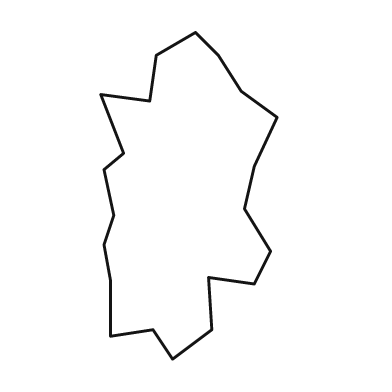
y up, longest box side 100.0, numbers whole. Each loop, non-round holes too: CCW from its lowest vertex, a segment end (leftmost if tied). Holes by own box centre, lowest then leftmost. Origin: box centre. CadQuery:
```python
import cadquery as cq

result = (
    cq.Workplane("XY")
    .moveTo(-5.0, -50.0)
    .lineTo(7.0, -41.0)
    .lineTo(6.0, -25.0)
    .lineTo(20.0, -27.0)
    .lineTo(25.0, -17.0)
    .lineTo(17.0, -4.0)
    .lineTo(20.0, 9.0)
    .lineTo(27.0, 24.0)
    .lineTo(16.0, 32.0)
    .lineTo(9.0, 43.0)
    .lineTo(2.0, 50.0)
    .lineTo(-10.0, 43.0)
    .lineTo(-12.0, 29.0)
    .lineTo(-27.0, 31.0)
    .lineTo(-20.0, 13.0)
    .lineTo(-26.0, 8.0)
    .lineTo(-23.0, -6.0)
    .lineTo(-26.0, -15.0)
    .lineTo(-24.0, -26.0)
    .lineTo(-24.0, -43.0)
    .lineTo(-11.0, -41.0)
    .close()
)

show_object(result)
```